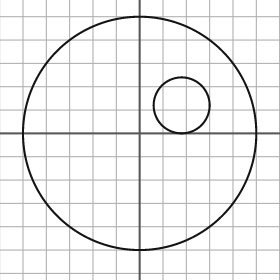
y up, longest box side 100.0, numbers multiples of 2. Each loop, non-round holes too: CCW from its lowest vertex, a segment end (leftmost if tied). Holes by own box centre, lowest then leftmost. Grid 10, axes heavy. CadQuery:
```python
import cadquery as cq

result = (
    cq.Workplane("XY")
    .moveTo(0.0, 0.0)
    .circle(50.0)
    .moveTo(18.0, 12.0)
    .circle(12.0)
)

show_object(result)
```